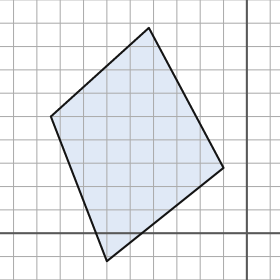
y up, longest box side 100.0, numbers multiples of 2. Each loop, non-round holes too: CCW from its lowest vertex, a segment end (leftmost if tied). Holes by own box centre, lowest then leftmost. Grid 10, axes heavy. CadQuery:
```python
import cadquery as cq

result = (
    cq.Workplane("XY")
    .moveTo(-60.0, -12.0)
    .lineTo(-10.0, 28.0)
    .lineTo(-42.0, 88.0)
    .lineTo(-84.0, 50.0)
    .close()
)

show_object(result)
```